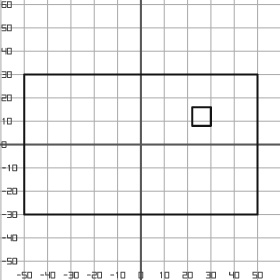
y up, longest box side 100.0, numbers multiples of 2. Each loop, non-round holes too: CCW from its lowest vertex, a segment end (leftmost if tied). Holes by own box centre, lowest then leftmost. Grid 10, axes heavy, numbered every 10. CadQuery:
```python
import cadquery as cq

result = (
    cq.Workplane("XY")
    .moveTo(-50.0, -30.0)
    .lineTo(50.0, -30.0)
    .lineTo(50.0, 30.0)
    .lineTo(-50.0, 30.0)
    .close()
    .moveTo(22.0, 8.0)
    .lineTo(30.0, 8.0)
    .lineTo(30.0, 16.0)
    .lineTo(22.0, 16.0)
    .close()
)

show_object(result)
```